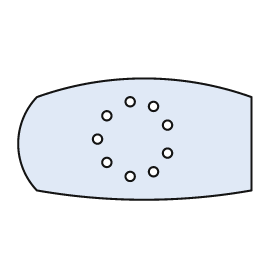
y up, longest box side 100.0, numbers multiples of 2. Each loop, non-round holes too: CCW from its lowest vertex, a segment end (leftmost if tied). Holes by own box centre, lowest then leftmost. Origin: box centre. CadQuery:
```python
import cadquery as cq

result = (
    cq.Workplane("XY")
    .moveTo(-42.0, -22.0)
    .threePointArc((4.0, -26.0), (50.0, -22.0))
    .lineTo(50.0, 18.0)
    .threePointArc((4.0, 26.0), (-42.0, 18.0))
    .threePointArc((-50.0, -2.0), (-42.0, -22.0))
    .close()
    .moveTo(-2.0, -16.0)
    .circle(2.0)
    .moveTo(8.0, -14.0)
    .circle(2.0)
    .moveTo(-12.0, -10.0)
    .circle(2.0)
    .moveTo(14.0, -6.0)
    .circle(2.0)
    .moveTo(-16.0, 0.0)
    .circle(2.0)
    .moveTo(14.0, 6.0)
    .circle(2.0)
    .moveTo(-12.0, 10.0)
    .circle(2.0)
    .moveTo(8.0, 14.0)
    .circle(2.0)
    .moveTo(-2.0, 16.0)
    .circle(2.0)
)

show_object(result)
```